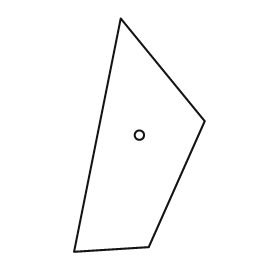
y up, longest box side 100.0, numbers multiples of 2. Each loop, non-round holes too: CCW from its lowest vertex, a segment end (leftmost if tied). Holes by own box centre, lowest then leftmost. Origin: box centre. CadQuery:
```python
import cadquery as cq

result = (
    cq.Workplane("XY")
    .moveTo(-28.0, -50.0)
    .lineTo(4.0, -48.0)
    .lineTo(28.0, 6.0)
    .lineTo(-8.0, 50.0)
    .close()
    .moveTo(0.0, 0.0)
    .circle(2.0)
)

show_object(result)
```